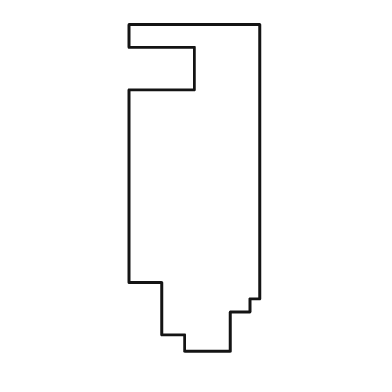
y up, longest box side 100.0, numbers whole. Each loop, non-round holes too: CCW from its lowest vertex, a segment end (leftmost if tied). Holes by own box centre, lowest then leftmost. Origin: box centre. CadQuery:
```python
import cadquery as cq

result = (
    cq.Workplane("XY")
    .moveTo(-3.0, -50.0)
    .lineTo(11.0, -50.0)
    .lineTo(11.0, -38.0)
    .lineTo(17.0, -38.0)
    .lineTo(17.0, -34.0)
    .lineTo(20.0, -34.0)
    .lineTo(20.0, 50.0)
    .lineTo(-20.0, 50.0)
    .lineTo(-20.0, 43.0)
    .lineTo(0.0, 43.0)
    .lineTo(0.0, 30.0)
    .lineTo(-20.0, 30.0)
    .lineTo(-20.0, -29.0)
    .lineTo(-10.0, -29.0)
    .lineTo(-10.0, -45.0)
    .lineTo(-3.0, -45.0)
    .close()
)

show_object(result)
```